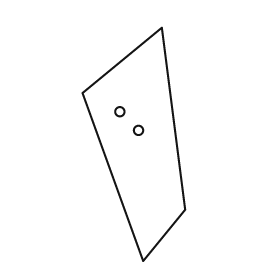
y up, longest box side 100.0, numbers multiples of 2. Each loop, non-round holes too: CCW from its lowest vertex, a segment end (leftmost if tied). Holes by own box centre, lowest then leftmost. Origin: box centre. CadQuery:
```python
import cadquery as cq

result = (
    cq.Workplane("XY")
    .moveTo(4.0, -50.0)
    .lineTo(22.0, -28.0)
    .lineTo(12.0, 50.0)
    .lineTo(-22.0, 22.0)
    .close()
    .moveTo(2.0, 6.0)
    .circle(2.0)
    .moveTo(-6.0, 14.0)
    .circle(2.0)
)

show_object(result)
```